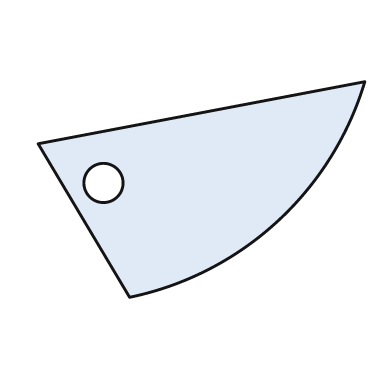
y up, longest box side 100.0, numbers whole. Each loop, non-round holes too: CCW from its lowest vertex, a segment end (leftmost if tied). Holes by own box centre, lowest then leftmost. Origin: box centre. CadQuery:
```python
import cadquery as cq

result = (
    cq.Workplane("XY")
    .moveTo(-22.0, -33.0)
    .threePointArc((23.0, -10.0), (50.0, 33.0))
    .lineTo(-50.0, 14.0)
    .close()
    .moveTo(-30.0, 2.0)
    .circle(6.0)
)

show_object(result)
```